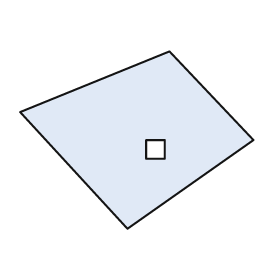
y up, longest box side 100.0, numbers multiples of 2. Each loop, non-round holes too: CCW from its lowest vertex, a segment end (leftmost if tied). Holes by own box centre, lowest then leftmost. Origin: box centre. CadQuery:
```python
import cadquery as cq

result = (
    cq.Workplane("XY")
    .moveTo(-4.0, -38.0)
    .lineTo(50.0, 0.0)
    .lineTo(14.0, 38.0)
    .lineTo(-50.0, 12.0)
    .close()
    .moveTo(4.0, -8.0)
    .lineTo(12.0, -8.0)
    .lineTo(12.0, 0.0)
    .lineTo(4.0, 0.0)
    .close()
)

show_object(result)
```